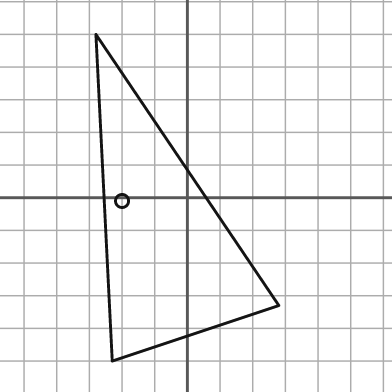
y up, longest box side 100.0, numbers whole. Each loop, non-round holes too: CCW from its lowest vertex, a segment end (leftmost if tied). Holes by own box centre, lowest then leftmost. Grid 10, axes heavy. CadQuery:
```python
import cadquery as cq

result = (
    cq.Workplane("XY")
    .moveTo(-23.0, -50.0)
    .lineTo(28.0, -33.0)
    .lineTo(-28.0, 50.0)
    .close()
    .moveTo(-20.0, -1.0)
    .circle(2.0)
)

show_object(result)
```